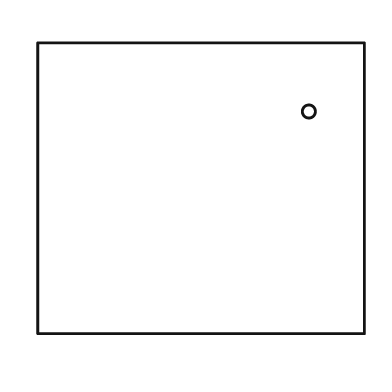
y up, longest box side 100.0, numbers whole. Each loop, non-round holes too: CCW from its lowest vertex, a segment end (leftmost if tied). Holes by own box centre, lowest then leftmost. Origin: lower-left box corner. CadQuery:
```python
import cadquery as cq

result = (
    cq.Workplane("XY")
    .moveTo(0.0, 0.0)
    .lineTo(100.0, 0.0)
    .lineTo(100.0, 89.0)
    .lineTo(0.0, 89.0)
    .close()
    .moveTo(83.0, 68.0)
    .circle(2.0)
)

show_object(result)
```